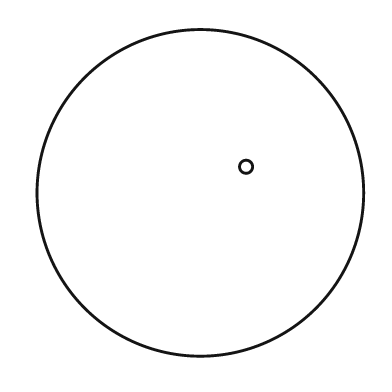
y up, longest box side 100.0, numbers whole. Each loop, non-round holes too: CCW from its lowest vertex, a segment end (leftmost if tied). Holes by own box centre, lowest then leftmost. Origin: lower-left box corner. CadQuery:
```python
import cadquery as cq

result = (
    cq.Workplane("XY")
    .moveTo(50.0, 50.0)
    .circle(50.0)
    .moveTo(64.0, 58.0)
    .circle(2.0)
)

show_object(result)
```